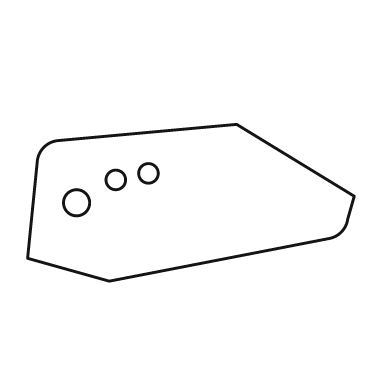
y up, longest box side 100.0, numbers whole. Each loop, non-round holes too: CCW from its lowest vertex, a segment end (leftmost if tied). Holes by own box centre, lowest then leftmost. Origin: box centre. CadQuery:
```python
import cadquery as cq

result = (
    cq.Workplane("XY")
    .moveTo(-25.0, -24.0)
    .lineTo(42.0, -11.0)
    .threePointArc((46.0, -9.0), (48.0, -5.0))
    .lineTo(50.0, 2.0)
    .lineTo(14.0, 24.0)
    .lineTo(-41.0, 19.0)
    .threePointArc((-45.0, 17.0), (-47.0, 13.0))
    .lineTo(-50.0, -17.0)
    .close()
    .moveTo(-35.0, 0.0)
    .circle(4.0)
    .moveTo(-23.0, 7.0)
    .circle(3.0)
    .moveTo(-13.0, 9.0)
    .circle(3.0)
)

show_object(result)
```